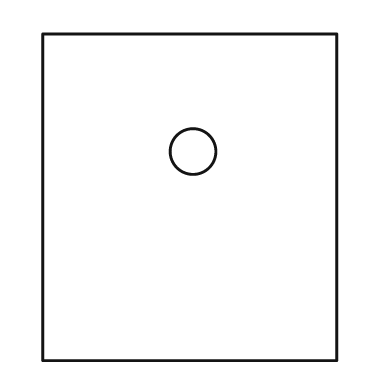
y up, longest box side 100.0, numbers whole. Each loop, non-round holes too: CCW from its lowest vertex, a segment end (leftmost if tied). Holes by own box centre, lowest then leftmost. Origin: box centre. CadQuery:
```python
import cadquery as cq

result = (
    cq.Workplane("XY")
    .moveTo(-45.0, -50.0)
    .lineTo(45.0, -50.0)
    .lineTo(45.0, 50.0)
    .lineTo(-45.0, 50.0)
    .close()
    .moveTo(1.0, 14.0)
    .circle(7.0)
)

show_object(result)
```